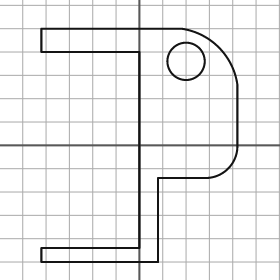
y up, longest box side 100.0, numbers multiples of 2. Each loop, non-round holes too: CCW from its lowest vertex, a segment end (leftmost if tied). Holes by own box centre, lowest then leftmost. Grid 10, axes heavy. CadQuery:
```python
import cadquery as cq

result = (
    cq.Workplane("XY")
    .moveTo(-42.0, -50.0)
    .lineTo(8.0, -50.0)
    .lineTo(8.0, -14.0)
    .lineTo(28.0, -14.0)
    .threePointArc((38.0, -10.0), (42.0, 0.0))
    .lineTo(42.0, 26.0)
    .threePointArc((34.0, 42.0), (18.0, 50.0))
    .lineTo(-42.0, 50.0)
    .lineTo(-42.0, 40.0)
    .lineTo(0.0, 40.0)
    .lineTo(0.0, -44.0)
    .lineTo(-42.0, -44.0)
    .close()
    .moveTo(20.0, 36.0)
    .circle(8.0)
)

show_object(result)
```